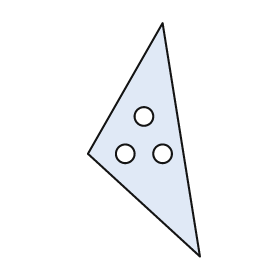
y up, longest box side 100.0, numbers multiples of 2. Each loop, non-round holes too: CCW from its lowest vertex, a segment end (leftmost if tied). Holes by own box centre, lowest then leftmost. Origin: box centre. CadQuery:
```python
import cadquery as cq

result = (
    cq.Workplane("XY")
    .moveTo(24.0, -50.0)
    .lineTo(8.0, 50.0)
    .lineTo(-24.0, -6.0)
    .close()
    .moveTo(-8.0, -6.0)
    .circle(4.0)
    .moveTo(8.0, -6.0)
    .circle(4.0)
    .moveTo(0.0, 10.0)
    .circle(4.0)
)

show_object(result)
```